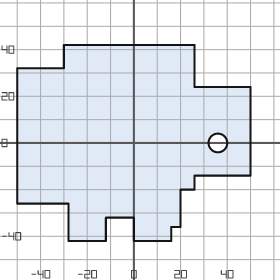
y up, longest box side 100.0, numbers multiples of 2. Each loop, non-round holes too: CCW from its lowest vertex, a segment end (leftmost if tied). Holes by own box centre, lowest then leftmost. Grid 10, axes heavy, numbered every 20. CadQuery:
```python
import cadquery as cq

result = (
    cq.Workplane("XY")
    .moveTo(-28.0, -42.0)
    .lineTo(-12.0, -42.0)
    .lineTo(-12.0, -32.0)
    .lineTo(0.0, -32.0)
    .lineTo(0.0, -42.0)
    .lineTo(16.0, -42.0)
    .lineTo(16.0, -36.0)
    .lineTo(20.0, -36.0)
    .lineTo(20.0, -20.0)
    .lineTo(26.0, -20.0)
    .lineTo(26.0, -14.0)
    .lineTo(50.0, -14.0)
    .lineTo(50.0, 24.0)
    .lineTo(26.0, 24.0)
    .lineTo(26.0, 42.0)
    .lineTo(-30.0, 42.0)
    .lineTo(-30.0, 32.0)
    .lineTo(-50.0, 32.0)
    .lineTo(-50.0, -26.0)
    .lineTo(-28.0, -26.0)
    .close()
    .moveTo(36.0, 0.0)
    .circle(4.0)
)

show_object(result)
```